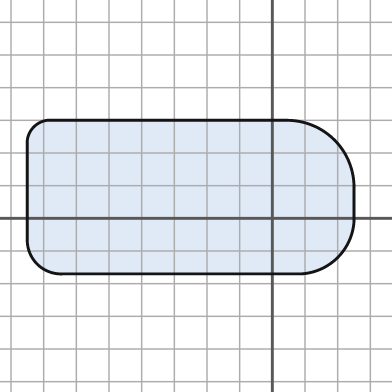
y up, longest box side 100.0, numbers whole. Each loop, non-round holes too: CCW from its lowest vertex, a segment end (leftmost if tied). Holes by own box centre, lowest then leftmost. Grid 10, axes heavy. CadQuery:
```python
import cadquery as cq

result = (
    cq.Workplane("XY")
    .moveTo(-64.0, -17.0)
    .lineTo(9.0, -17.0)
    .threePointArc((20.0, -12.0), (25.0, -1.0))
    .lineTo(25.0, 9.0)
    .threePointArc((19.0, 24.0), (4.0, 30.0))
    .lineTo(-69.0, 30.0)
    .threePointArc((-73.0, 28.0), (-75.0, 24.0))
    .lineTo(-75.0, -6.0)
    .threePointArc((-72.0, -14.0), (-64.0, -17.0))
    .close()
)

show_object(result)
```